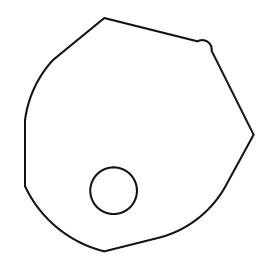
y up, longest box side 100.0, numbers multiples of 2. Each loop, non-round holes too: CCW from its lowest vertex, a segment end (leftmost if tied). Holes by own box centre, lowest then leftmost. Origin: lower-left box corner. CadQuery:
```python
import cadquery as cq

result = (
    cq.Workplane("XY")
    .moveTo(34.0, 0.0)
    .lineTo(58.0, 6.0)
    .threePointArc((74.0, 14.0), (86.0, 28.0))
    .lineTo(98.0, 50.0)
    .lineTo(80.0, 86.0)
    .threePointArc((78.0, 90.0), (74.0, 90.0))
    .lineTo(34.0, 100.0)
    .lineTo(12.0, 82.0)
    .threePointArc((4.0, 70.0), (0.0, 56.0))
    .lineTo(0.0, 28.0)
    .threePointArc((14.0, 10.0), (34.0, 0.0))
    .close()
    .moveTo(38.0, 26.0)
    .circle(10.0)
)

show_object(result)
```